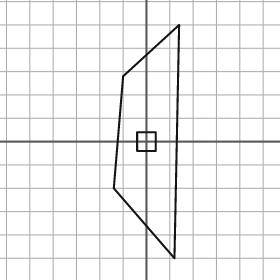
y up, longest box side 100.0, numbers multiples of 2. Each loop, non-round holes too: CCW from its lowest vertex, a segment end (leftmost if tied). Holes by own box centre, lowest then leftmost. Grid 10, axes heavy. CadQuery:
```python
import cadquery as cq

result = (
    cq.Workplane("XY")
    .moveTo(12.0, -50.0)
    .lineTo(14.0, 50.0)
    .lineTo(-10.0, 28.0)
    .lineTo(-14.0, -20.0)
    .close()
    .moveTo(-4.0, -4.0)
    .lineTo(4.0, -4.0)
    .lineTo(4.0, 4.0)
    .lineTo(-4.0, 4.0)
    .close()
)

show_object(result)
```